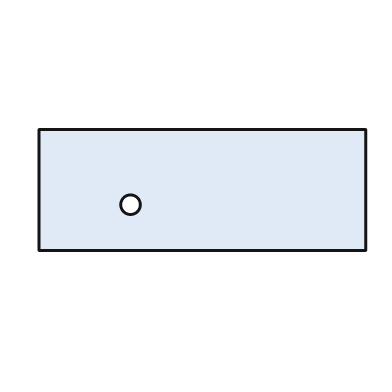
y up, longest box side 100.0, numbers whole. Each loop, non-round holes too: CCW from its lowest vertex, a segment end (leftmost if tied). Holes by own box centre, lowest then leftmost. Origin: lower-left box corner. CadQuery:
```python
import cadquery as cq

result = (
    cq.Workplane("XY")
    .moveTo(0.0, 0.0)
    .lineTo(100.0, 0.0)
    .lineTo(100.0, 37.0)
    .lineTo(0.0, 37.0)
    .close()
    .moveTo(28.0, 14.0)
    .circle(3.0)
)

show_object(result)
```